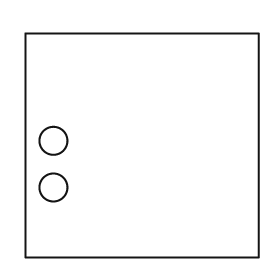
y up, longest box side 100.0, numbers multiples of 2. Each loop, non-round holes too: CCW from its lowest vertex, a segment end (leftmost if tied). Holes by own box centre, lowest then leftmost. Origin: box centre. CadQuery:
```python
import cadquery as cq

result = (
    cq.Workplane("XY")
    .moveTo(-50.0, -48.0)
    .lineTo(50.0, -48.0)
    .lineTo(50.0, 48.0)
    .lineTo(-50.0, 48.0)
    .close()
    .moveTo(-38.0, -18.0)
    .circle(6.0)
    .moveTo(-38.0, 2.0)
    .circle(6.0)
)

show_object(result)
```